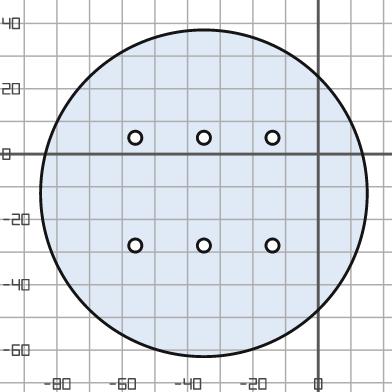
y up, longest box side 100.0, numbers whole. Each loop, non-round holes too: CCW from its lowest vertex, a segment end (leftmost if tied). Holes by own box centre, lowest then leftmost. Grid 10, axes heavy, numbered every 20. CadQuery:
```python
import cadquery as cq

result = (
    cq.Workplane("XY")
    .moveTo(-35.0, -12.0)
    .circle(50.0)
    .moveTo(-56.0, -28.0)
    .circle(2.0)
    .moveTo(-35.0, -28.0)
    .circle(2.0)
    .moveTo(-14.0, -28.0)
    .circle(2.0)
    .moveTo(-56.0, 5.0)
    .circle(2.0)
    .moveTo(-35.0, 5.0)
    .circle(2.0)
    .moveTo(-14.0, 5.0)
    .circle(2.0)
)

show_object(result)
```